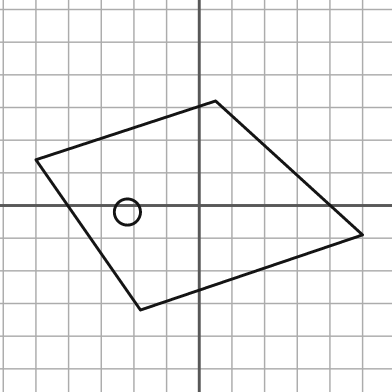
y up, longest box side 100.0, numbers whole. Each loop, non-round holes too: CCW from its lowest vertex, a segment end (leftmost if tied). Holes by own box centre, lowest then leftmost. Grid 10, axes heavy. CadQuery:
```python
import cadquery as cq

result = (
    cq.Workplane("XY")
    .moveTo(-18.0, -32.0)
    .lineTo(50.0, -9.0)
    .lineTo(5.0, 32.0)
    .lineTo(-50.0, 14.0)
    .close()
    .moveTo(-22.0, -2.0)
    .circle(4.0)
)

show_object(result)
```